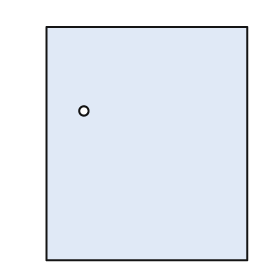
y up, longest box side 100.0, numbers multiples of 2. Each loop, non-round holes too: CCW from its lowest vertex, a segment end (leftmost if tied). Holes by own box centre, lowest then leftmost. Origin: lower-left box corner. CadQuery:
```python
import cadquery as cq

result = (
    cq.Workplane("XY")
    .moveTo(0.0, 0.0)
    .lineTo(86.0, 0.0)
    .lineTo(86.0, 100.0)
    .lineTo(0.0, 100.0)
    .close()
    .moveTo(16.0, 64.0)
    .circle(2.0)
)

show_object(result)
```